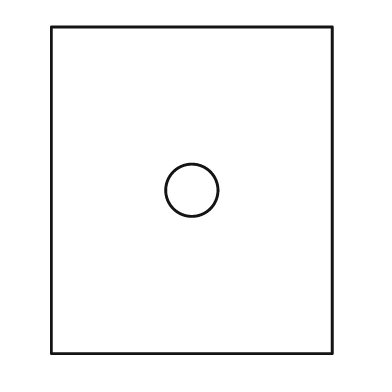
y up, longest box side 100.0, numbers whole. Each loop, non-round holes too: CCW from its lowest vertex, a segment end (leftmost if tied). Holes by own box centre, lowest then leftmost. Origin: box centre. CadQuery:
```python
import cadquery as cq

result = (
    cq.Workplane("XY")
    .moveTo(-43.0, -50.0)
    .lineTo(43.0, -50.0)
    .lineTo(43.0, 50.0)
    .lineTo(-43.0, 50.0)
    .close()
    .moveTo(0.0, 0.0)
    .circle(8.0)
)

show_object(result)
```